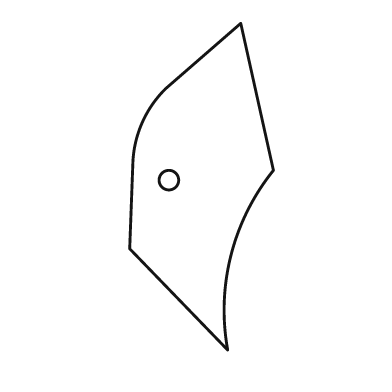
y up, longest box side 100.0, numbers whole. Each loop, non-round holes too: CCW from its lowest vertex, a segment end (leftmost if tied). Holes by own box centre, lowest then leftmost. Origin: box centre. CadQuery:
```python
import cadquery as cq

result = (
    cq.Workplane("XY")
    .moveTo(8.0, -50.0)
    .threePointArc((9.0, -21.0), (22.0, 5.0))
    .lineTo(12.0, 50.0)
    .lineTo(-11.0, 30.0)
    .threePointArc((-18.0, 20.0), (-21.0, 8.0))
    .lineTo(-22.0, -19.0)
    .close()
    .moveTo(-10.0, 2.0)
    .circle(3.0)
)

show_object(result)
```